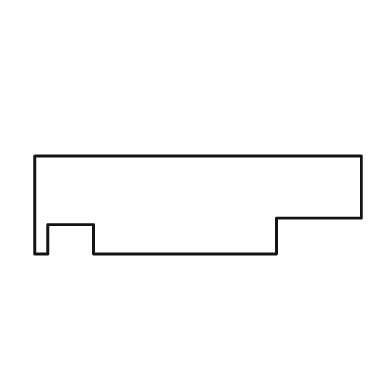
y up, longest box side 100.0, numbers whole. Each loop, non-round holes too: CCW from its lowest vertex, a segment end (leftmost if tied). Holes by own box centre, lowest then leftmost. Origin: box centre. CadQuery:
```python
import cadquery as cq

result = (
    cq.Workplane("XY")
    .moveTo(-50.0, -15.0)
    .lineTo(-46.0, -15.0)
    .lineTo(-46.0, -6.0)
    .lineTo(-32.0, -6.0)
    .lineTo(-32.0, -15.0)
    .lineTo(24.0, -15.0)
    .lineTo(24.0, -4.0)
    .lineTo(50.0, -4.0)
    .lineTo(50.0, 15.0)
    .lineTo(-50.0, 15.0)
    .close()
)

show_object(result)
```